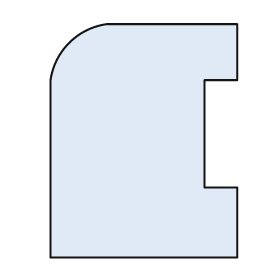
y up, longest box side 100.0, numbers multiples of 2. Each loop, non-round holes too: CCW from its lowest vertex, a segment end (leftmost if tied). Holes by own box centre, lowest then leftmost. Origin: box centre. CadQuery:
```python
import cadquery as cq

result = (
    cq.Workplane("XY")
    .moveTo(-40.0, -50.0)
    .lineTo(40.0, -50.0)
    .lineTo(40.0, -20.0)
    .lineTo(26.0, -20.0)
    .lineTo(26.0, 26.0)
    .lineTo(40.0, 26.0)
    .lineTo(40.0, 50.0)
    .lineTo(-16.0, 50.0)
    .threePointArc((-32.0, 42.0), (-40.0, 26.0))
    .close()
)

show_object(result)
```